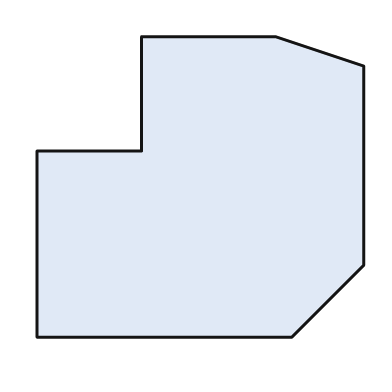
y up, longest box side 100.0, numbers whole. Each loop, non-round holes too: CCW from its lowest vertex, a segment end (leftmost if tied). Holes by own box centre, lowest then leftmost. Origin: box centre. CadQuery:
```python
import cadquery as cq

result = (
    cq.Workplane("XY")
    .moveTo(-50.0, -46.0)
    .lineTo(28.0, -46.0)
    .lineTo(50.0, -24.0)
    .lineTo(50.0, 37.0)
    .lineTo(23.0, 46.0)
    .lineTo(-18.0, 46.0)
    .lineTo(-18.0, 11.0)
    .lineTo(-50.0, 11.0)
    .close()
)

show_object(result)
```